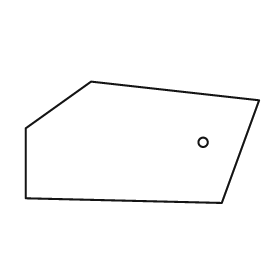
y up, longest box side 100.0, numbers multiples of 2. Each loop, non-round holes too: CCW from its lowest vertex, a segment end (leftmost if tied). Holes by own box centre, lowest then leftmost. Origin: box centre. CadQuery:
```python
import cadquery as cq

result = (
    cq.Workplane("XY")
    .moveTo(34.0, -26.0)
    .lineTo(50.0, 18.0)
    .lineTo(-22.0, 26.0)
    .lineTo(-50.0, 6.0)
    .lineTo(-50.0, -24.0)
    .close()
    .moveTo(26.0, 0.0)
    .circle(2.0)
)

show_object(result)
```